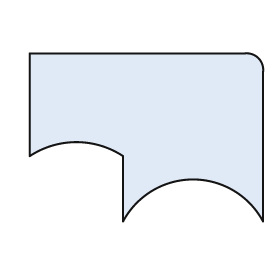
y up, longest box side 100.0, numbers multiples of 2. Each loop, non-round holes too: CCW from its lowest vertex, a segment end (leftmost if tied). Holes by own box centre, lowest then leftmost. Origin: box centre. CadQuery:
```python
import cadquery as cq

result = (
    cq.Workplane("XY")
    .moveTo(-10.0, -36.0)
    .threePointArc((20.0, -18.0), (50.0, -36.0))
    .lineTo(50.0, 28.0)
    .threePointArc((48.0, 34.0), (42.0, 36.0))
    .lineTo(-50.0, 36.0)
    .lineTo(-50.0, -8.0)
    .threePointArc((-30.0, -2.0), (-10.0, -8.0))
    .close()
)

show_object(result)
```